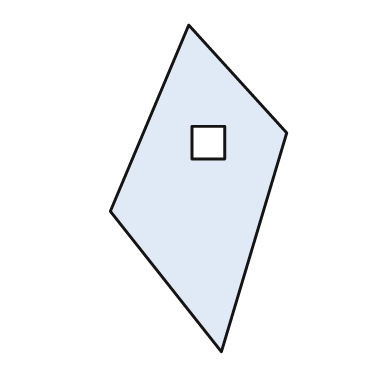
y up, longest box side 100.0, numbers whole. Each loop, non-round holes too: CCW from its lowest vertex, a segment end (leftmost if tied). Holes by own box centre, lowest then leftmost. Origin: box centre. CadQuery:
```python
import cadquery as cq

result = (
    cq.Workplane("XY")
    .moveTo(7.0, -50.0)
    .lineTo(27.0, 17.0)
    .lineTo(-3.0, 50.0)
    .lineTo(-27.0, -7.0)
    .close()
    .moveTo(-2.0, 9.0)
    .lineTo(8.0, 9.0)
    .lineTo(8.0, 19.0)
    .lineTo(-2.0, 19.0)
    .close()
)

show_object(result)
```